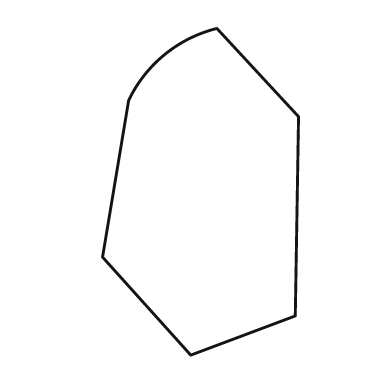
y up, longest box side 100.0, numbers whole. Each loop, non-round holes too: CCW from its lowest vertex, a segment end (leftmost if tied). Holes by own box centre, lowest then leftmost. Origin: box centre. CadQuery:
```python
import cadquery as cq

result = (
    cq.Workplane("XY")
    .moveTo(-3.0, -50.0)
    .lineTo(29.0, -38.0)
    .lineTo(30.0, 23.0)
    .lineTo(5.0, 50.0)
    .threePointArc((-11.0, 42.0), (-22.0, 28.0))
    .lineTo(-30.0, -20.0)
    .close()
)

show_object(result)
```